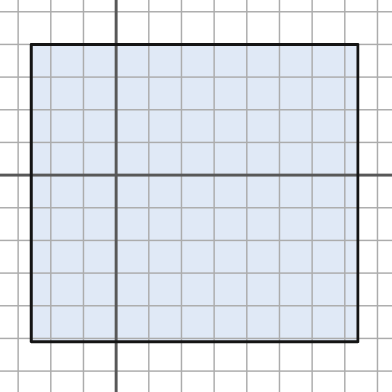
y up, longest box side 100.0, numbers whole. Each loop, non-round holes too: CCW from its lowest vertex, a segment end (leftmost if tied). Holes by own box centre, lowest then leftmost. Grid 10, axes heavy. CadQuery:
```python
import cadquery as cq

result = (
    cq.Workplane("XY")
    .moveTo(-26.0, -51.0)
    .lineTo(74.0, -51.0)
    .lineTo(74.0, 40.0)
    .lineTo(-26.0, 40.0)
    .close()
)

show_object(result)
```